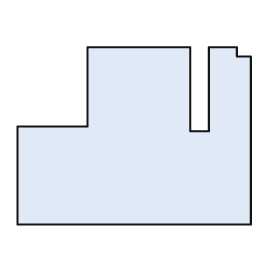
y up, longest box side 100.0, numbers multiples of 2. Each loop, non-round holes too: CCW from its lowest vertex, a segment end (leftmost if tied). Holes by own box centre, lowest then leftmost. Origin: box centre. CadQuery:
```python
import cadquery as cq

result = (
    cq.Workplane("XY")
    .moveTo(-50.0, -38.0)
    .lineTo(50.0, -38.0)
    .lineTo(50.0, 34.0)
    .lineTo(44.0, 34.0)
    .lineTo(44.0, 38.0)
    .lineTo(32.0, 38.0)
    .lineTo(32.0, 2.0)
    .lineTo(24.0, 2.0)
    .lineTo(24.0, 38.0)
    .lineTo(-20.0, 38.0)
    .lineTo(-20.0, 4.0)
    .lineTo(-50.0, 4.0)
    .close()
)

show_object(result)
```